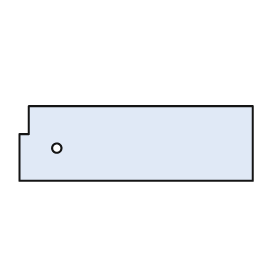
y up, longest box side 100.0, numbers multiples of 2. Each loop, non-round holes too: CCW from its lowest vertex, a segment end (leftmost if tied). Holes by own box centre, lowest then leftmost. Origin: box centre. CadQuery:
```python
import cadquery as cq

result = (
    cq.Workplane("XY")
    .moveTo(-50.0, -16.0)
    .lineTo(50.0, -16.0)
    .lineTo(50.0, 16.0)
    .lineTo(-46.0, 16.0)
    .lineTo(-46.0, 4.0)
    .lineTo(-50.0, 4.0)
    .close()
    .moveTo(-34.0, -2.0)
    .circle(2.0)
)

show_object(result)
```